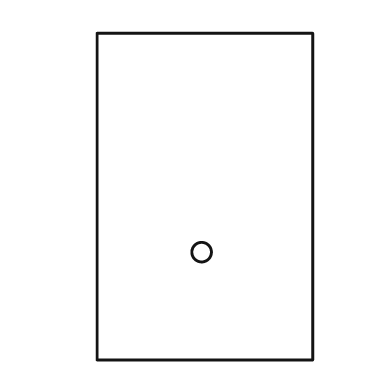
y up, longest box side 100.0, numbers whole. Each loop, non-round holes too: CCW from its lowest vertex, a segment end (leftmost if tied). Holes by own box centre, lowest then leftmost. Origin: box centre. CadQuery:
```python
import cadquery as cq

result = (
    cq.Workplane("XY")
    .moveTo(-33.0, -50.0)
    .lineTo(33.0, -50.0)
    .lineTo(33.0, 50.0)
    .lineTo(-33.0, 50.0)
    .close()
    .moveTo(-1.0, -17.0)
    .circle(3.0)
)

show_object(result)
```